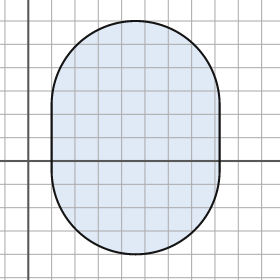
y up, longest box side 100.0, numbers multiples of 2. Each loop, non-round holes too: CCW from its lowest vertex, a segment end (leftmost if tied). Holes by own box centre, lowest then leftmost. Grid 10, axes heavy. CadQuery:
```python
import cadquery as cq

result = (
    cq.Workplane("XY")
    .moveTo(10.0, -4.0)
    .threePointArc((46.0, -40.0), (82.0, -4.0))
    .lineTo(82.0, 24.0)
    .threePointArc((46.0, 60.0), (10.0, 24.0))
    .close()
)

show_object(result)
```